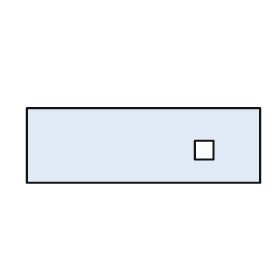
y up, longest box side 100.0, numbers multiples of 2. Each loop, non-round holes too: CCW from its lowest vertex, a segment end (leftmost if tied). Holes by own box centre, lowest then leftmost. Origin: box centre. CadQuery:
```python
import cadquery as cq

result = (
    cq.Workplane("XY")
    .moveTo(-50.0, -16.0)
    .lineTo(50.0, -16.0)
    .lineTo(50.0, 16.0)
    .lineTo(-50.0, 16.0)
    .close()
    .moveTo(22.0, -6.0)
    .lineTo(30.0, -6.0)
    .lineTo(30.0, 2.0)
    .lineTo(22.0, 2.0)
    .close()
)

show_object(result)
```